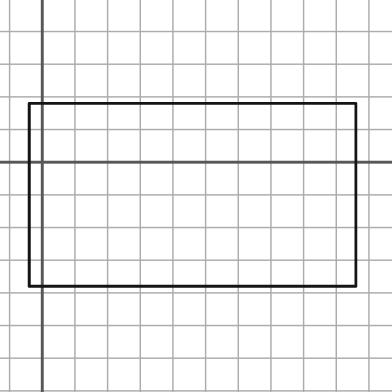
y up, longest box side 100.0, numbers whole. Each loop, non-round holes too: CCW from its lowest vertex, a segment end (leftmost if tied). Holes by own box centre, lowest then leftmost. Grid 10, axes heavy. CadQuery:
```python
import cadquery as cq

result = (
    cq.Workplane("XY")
    .moveTo(-4.0, -38.0)
    .lineTo(96.0, -38.0)
    .lineTo(96.0, 18.0)
    .lineTo(-4.0, 18.0)
    .close()
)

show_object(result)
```